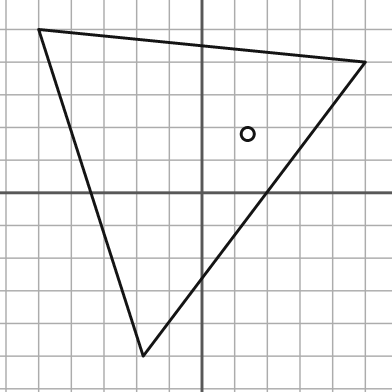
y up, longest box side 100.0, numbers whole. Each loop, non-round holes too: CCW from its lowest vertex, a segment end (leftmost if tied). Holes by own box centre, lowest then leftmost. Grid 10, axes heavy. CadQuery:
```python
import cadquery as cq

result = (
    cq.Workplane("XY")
    .moveTo(-18.0, -50.0)
    .lineTo(50.0, 40.0)
    .lineTo(-50.0, 50.0)
    .close()
    .moveTo(14.0, 18.0)
    .circle(2.0)
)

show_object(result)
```